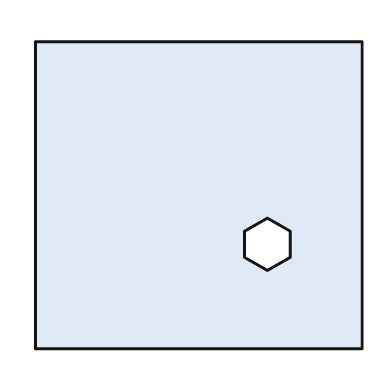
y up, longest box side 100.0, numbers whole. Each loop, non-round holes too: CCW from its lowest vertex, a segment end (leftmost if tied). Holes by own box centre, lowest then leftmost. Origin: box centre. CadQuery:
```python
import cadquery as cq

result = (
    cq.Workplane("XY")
    .moveTo(-50.0, -47.0)
    .lineTo(50.0, -47.0)
    .lineTo(50.0, 47.0)
    .lineTo(-50.0, 47.0)
    .close()
    .moveTo(21.0, -23.0)
    .lineTo(28.0, -19.0)
    .lineTo(28.0, -11.0)
    .lineTo(21.0, -7.0)
    .lineTo(14.0, -11.0)
    .lineTo(14.0, -19.0)
    .close()
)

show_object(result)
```